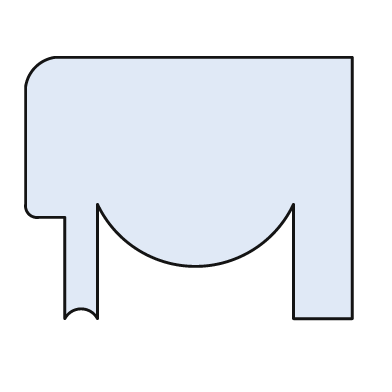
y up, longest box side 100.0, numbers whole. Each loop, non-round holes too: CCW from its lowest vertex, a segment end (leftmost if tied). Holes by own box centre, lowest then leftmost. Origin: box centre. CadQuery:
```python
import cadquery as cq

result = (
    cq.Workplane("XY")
    .moveTo(-38.0, -40.0)
    .threePointArc((-33.0, -37.0), (-28.0, -40.0))
    .lineTo(-28.0, -5.0)
    .threePointArc((2.0, -24.0), (32.0, -5.0))
    .lineTo(32.0, -40.0)
    .lineTo(50.0, -40.0)
    .lineTo(50.0, 40.0)
    .lineTo(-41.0, 40.0)
    .threePointArc((-47.0, 37.0), (-50.0, 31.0))
    .lineTo(-50.0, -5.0)
    .threePointArc((-49.0, -8.0), (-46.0, -9.0))
    .lineTo(-38.0, -9.0)
    .close()
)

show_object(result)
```